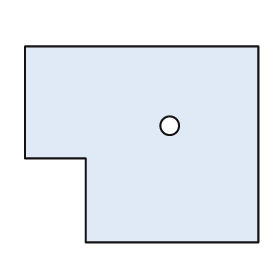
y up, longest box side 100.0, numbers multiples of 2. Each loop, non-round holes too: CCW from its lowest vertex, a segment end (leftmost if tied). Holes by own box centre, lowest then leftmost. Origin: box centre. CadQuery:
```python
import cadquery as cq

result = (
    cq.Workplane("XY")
    .moveTo(-24.0, -42.0)
    .lineTo(50.0, -42.0)
    .lineTo(50.0, 42.0)
    .lineTo(-50.0, 42.0)
    .lineTo(-50.0, -6.0)
    .lineTo(-24.0, -6.0)
    .close()
    .moveTo(12.0, 8.0)
    .circle(4.0)
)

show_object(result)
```